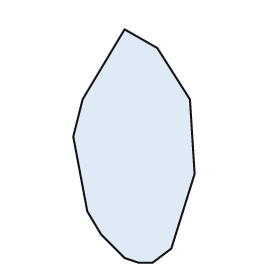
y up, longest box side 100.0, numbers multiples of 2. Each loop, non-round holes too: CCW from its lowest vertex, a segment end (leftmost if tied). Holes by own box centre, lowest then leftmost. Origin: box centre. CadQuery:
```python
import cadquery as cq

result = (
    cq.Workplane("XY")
    .moveTo(2.0, -50.0)
    .lineTo(8.0, -50.0)
    .lineTo(16.0, -44.0)
    .lineTo(26.0, -12.0)
    .lineTo(24.0, 20.0)
    .lineTo(10.0, 42.0)
    .lineTo(-4.0, 50.0)
    .lineTo(-22.0, 20.0)
    .lineTo(-26.0, 4.0)
    .lineTo(-20.0, -28.0)
    .lineTo(-14.0, -38.0)
    .lineTo(-4.0, -48.0)
    .close()
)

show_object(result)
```